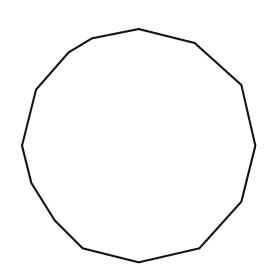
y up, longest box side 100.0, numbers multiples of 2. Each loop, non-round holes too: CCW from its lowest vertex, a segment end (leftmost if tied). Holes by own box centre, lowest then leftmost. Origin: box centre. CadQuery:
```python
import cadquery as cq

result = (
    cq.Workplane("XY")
    .moveTo(0.0, -50.0)
    .lineTo(26.0, -44.0)
    .lineTo(44.0, -24.0)
    .lineTo(50.0, 0.0)
    .lineTo(44.0, 26.0)
    .lineTo(24.0, 44.0)
    .lineTo(0.0, 50.0)
    .lineTo(-20.0, 46.0)
    .lineTo(-30.0, 40.0)
    .lineTo(-44.0, 24.0)
    .lineTo(-50.0, 0.0)
    .lineTo(-46.0, -16.0)
    .lineTo(-36.0, -32.0)
    .lineTo(-24.0, -44.0)
    .close()
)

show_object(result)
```